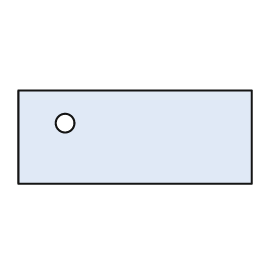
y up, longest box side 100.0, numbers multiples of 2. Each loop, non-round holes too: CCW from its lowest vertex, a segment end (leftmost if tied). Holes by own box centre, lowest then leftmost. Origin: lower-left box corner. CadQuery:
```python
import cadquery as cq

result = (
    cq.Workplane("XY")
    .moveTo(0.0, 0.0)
    .lineTo(100.0, 0.0)
    .lineTo(100.0, 40.0)
    .lineTo(0.0, 40.0)
    .close()
    .moveTo(20.0, 26.0)
    .circle(4.0)
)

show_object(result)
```